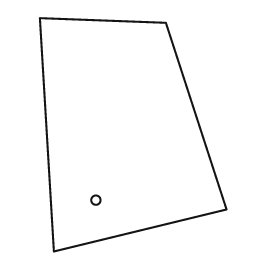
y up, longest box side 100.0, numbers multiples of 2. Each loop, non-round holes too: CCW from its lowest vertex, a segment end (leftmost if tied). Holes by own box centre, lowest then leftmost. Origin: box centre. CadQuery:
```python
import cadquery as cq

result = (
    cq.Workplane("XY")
    .moveTo(-34.0, -50.0)
    .lineTo(40.0, -32.0)
    .lineTo(14.0, 48.0)
    .lineTo(-40.0, 50.0)
    .close()
    .moveTo(-16.0, -28.0)
    .circle(2.0)
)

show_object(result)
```